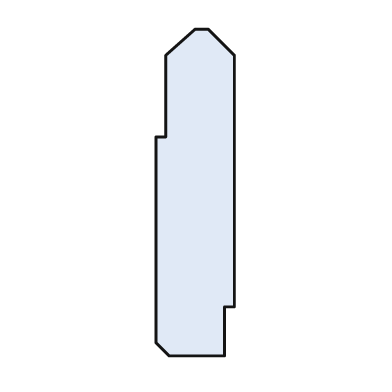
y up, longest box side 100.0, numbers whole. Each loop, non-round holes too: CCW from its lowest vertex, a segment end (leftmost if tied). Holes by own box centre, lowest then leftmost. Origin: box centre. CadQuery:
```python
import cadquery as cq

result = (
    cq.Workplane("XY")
    .moveTo(-8.0, -50.0)
    .lineTo(9.0, -50.0)
    .lineTo(9.0, -35.0)
    .lineTo(12.0, -35.0)
    .lineTo(12.0, 42.0)
    .lineTo(4.0, 50.0)
    .lineTo(0.0, 50.0)
    .lineTo(-9.0, 42.0)
    .lineTo(-9.0, 17.0)
    .lineTo(-12.0, 17.0)
    .lineTo(-12.0, -46.0)
    .close()
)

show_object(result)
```